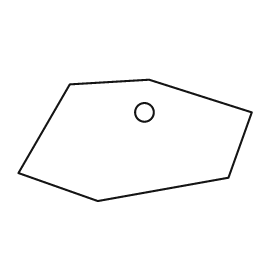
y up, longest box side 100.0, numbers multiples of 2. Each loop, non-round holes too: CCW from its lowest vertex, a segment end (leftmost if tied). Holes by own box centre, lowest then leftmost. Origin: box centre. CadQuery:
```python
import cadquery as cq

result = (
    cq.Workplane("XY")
    .moveTo(-16.0, -26.0)
    .lineTo(40.0, -16.0)
    .lineTo(50.0, 12.0)
    .lineTo(6.0, 26.0)
    .lineTo(-28.0, 24.0)
    .lineTo(-50.0, -14.0)
    .close()
    .moveTo(4.0, 12.0)
    .circle(4.0)
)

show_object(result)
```